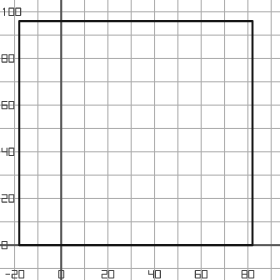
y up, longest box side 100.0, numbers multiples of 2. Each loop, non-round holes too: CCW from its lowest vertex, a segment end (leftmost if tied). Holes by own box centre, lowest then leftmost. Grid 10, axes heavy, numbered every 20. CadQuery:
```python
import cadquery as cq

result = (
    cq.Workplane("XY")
    .moveTo(-18.0, 0.0)
    .lineTo(82.0, 0.0)
    .lineTo(82.0, 96.0)
    .lineTo(-18.0, 96.0)
    .close()
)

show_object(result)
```